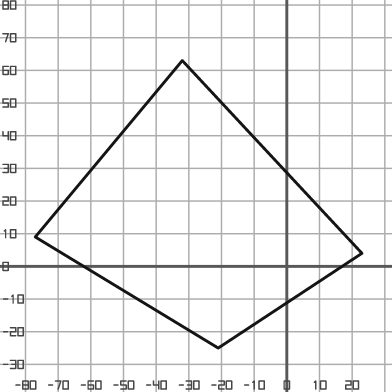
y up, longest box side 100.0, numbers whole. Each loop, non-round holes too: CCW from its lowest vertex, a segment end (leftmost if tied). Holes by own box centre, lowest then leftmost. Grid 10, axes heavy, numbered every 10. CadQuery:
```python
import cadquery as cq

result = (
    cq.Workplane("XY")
    .moveTo(-21.0, -25.0)
    .lineTo(23.0, 4.0)
    .lineTo(-32.0, 63.0)
    .lineTo(-77.0, 9.0)
    .close()
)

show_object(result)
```